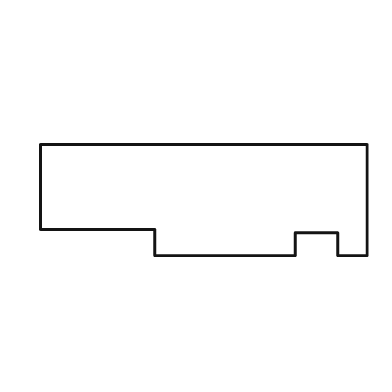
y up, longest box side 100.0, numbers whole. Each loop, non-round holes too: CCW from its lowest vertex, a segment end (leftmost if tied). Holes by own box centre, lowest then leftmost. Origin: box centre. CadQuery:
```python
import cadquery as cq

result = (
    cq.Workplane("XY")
    .moveTo(-15.0, -17.0)
    .lineTo(28.0, -17.0)
    .lineTo(28.0, -10.0)
    .lineTo(41.0, -10.0)
    .lineTo(41.0, -17.0)
    .lineTo(50.0, -17.0)
    .lineTo(50.0, 17.0)
    .lineTo(-50.0, 17.0)
    .lineTo(-50.0, -9.0)
    .lineTo(-15.0, -9.0)
    .close()
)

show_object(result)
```